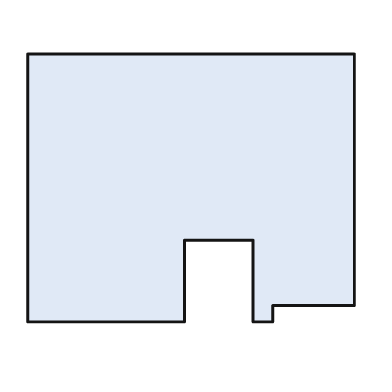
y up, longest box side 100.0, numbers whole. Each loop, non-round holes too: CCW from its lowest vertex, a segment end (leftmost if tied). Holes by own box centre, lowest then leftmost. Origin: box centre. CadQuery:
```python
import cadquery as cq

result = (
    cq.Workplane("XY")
    .moveTo(-50.0, -41.0)
    .lineTo(-2.0, -41.0)
    .lineTo(-2.0, -16.0)
    .lineTo(19.0, -16.0)
    .lineTo(19.0, -41.0)
    .lineTo(25.0, -41.0)
    .lineTo(25.0, -36.0)
    .lineTo(50.0, -36.0)
    .lineTo(50.0, 41.0)
    .lineTo(-50.0, 41.0)
    .close()
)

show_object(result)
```